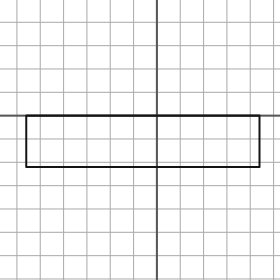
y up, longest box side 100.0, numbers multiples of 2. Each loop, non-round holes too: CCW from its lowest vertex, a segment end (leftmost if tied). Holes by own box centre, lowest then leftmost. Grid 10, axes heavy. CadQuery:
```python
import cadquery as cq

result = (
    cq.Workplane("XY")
    .moveTo(-56.0, -22.0)
    .lineTo(44.0, -22.0)
    .lineTo(44.0, 0.0)
    .lineTo(-56.0, 0.0)
    .close()
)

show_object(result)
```